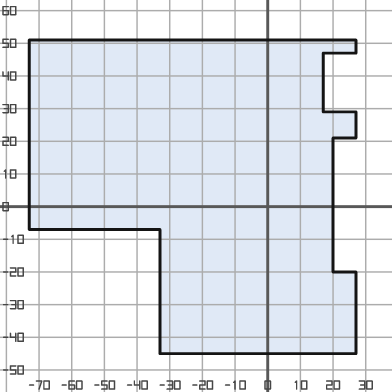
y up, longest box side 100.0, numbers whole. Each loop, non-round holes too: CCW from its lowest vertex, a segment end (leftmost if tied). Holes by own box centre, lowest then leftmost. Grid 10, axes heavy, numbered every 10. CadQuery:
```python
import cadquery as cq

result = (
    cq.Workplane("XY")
    .moveTo(-33.0, -45.0)
    .lineTo(27.0, -45.0)
    .lineTo(27.0, -20.0)
    .lineTo(20.0, -20.0)
    .lineTo(20.0, 21.0)
    .lineTo(27.0, 21.0)
    .lineTo(27.0, 29.0)
    .lineTo(17.0, 29.0)
    .lineTo(17.0, 47.0)
    .lineTo(27.0, 47.0)
    .lineTo(27.0, 51.0)
    .lineTo(-73.0, 51.0)
    .lineTo(-73.0, -7.0)
    .lineTo(-33.0, -7.0)
    .close()
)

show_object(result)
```